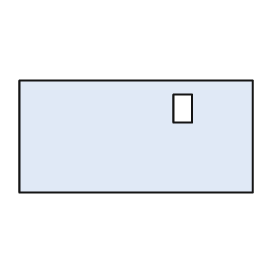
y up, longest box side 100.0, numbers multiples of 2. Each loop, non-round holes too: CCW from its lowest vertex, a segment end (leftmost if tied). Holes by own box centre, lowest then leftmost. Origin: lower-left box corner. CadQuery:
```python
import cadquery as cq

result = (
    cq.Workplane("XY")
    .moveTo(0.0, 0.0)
    .lineTo(100.0, 0.0)
    .lineTo(100.0, 48.0)
    .lineTo(0.0, 48.0)
    .close()
    .moveTo(66.0, 30.0)
    .lineTo(74.0, 30.0)
    .lineTo(74.0, 42.0)
    .lineTo(66.0, 42.0)
    .close()
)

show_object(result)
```